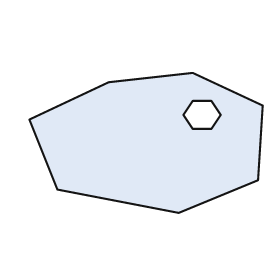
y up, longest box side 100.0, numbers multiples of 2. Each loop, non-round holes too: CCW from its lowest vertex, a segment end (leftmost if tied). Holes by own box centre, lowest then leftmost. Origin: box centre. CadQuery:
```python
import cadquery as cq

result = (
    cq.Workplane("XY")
    .moveTo(14.0, -30.0)
    .lineTo(48.0, -16.0)
    .lineTo(50.0, 16.0)
    .lineTo(20.0, 30.0)
    .lineTo(-16.0, 26.0)
    .lineTo(-50.0, 10.0)
    .lineTo(-38.0, -20.0)
    .close()
    .moveTo(20.0, 6.0)
    .lineTo(28.0, 6.0)
    .lineTo(32.0, 12.0)
    .lineTo(28.0, 18.0)
    .lineTo(20.0, 18.0)
    .lineTo(16.0, 12.0)
    .close()
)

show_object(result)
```